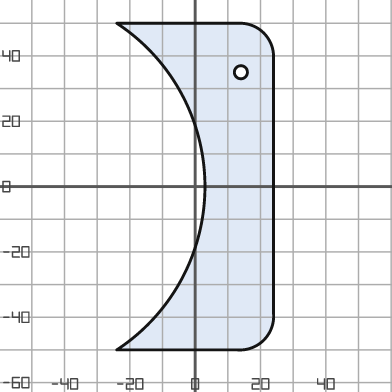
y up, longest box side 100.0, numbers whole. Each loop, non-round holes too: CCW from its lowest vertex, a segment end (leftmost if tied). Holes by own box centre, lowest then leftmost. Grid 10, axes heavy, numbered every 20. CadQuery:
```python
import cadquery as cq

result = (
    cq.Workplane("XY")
    .moveTo(-24.0, -50.0)
    .lineTo(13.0, -50.0)
    .threePointArc((21.0, -47.0), (24.0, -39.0))
    .lineTo(24.0, 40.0)
    .threePointArc((21.0, 47.0), (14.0, 50.0))
    .lineTo(-24.0, 50.0)
    .threePointArc((3.0, 0.0), (-24.0, -50.0))
    .close()
    .moveTo(14.0, 35.0)
    .circle(2.0)
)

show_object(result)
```